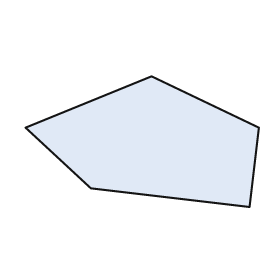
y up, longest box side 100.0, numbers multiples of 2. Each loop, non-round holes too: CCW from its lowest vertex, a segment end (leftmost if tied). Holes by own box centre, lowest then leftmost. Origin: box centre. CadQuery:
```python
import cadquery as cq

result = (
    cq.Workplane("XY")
    .moveTo(46.0, -28.0)
    .lineTo(50.0, 6.0)
    .lineTo(4.0, 28.0)
    .lineTo(-50.0, 6.0)
    .lineTo(-22.0, -20.0)
    .close()
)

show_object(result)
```